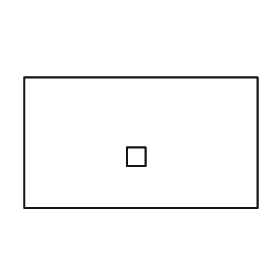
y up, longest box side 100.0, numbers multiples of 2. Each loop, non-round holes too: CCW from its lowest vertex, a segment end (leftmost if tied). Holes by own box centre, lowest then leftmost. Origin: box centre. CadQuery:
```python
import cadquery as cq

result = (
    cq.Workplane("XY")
    .moveTo(-50.0, -28.0)
    .lineTo(50.0, -28.0)
    .lineTo(50.0, 28.0)
    .lineTo(-50.0, 28.0)
    .close()
    .moveTo(-6.0, -10.0)
    .lineTo(2.0, -10.0)
    .lineTo(2.0, -2.0)
    .lineTo(-6.0, -2.0)
    .close()
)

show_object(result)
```